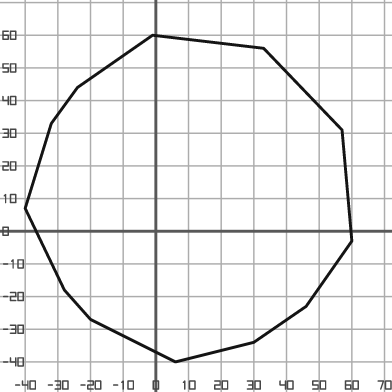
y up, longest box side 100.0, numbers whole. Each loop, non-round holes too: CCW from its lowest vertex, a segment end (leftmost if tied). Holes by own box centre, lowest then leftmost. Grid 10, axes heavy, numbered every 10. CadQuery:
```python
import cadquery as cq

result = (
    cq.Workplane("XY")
    .moveTo(6.0, -40.0)
    .lineTo(30.0, -34.0)
    .lineTo(46.0, -23.0)
    .lineTo(60.0, -3.0)
    .lineTo(57.0, 31.0)
    .lineTo(33.0, 56.0)
    .lineTo(-1.0, 60.0)
    .lineTo(-24.0, 44.0)
    .lineTo(-32.0, 33.0)
    .lineTo(-40.0, 7.0)
    .lineTo(-28.0, -18.0)
    .lineTo(-20.0, -27.0)
    .close()
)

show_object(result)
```